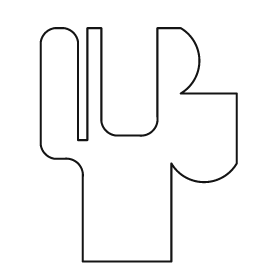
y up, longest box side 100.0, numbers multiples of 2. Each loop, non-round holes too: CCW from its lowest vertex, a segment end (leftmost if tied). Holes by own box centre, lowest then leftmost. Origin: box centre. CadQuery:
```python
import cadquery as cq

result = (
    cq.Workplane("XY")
    .moveTo(-24.0, -50.0)
    .lineTo(14.0, -50.0)
    .lineTo(14.0, -8.0)
    .threePointArc((28.0, -16.0), (42.0, -8.0))
    .lineTo(42.0, 22.0)
    .lineTo(18.0, 22.0)
    .threePointArc((26.0, 36.0), (18.0, 50.0))
    .lineTo(8.0, 50.0)
    .lineTo(8.0, 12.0)
    .threePointArc((6.0, 6.0), (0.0, 4.0))
    .lineTo(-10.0, 4.0)
    .threePointArc((-14.0, 6.0), (-16.0, 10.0))
    .lineTo(-16.0, 50.0)
    .lineTo(-22.0, 50.0)
    .lineTo(-22.0, 2.0)
    .lineTo(-26.0, 2.0)
    .lineTo(-26.0, 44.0)
    .threePointArc((-28.0, 48.0), (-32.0, 50.0))
    .lineTo(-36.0, 50.0)
    .threePointArc((-40.0, 48.0), (-42.0, 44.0))
    .lineTo(-42.0, 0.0)
    .threePointArc((-40.0, -4.0), (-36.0, -6.0))
    .lineTo(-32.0, -6.0)
    .threePointArc((-26.0, -8.0), (-24.0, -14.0))
    .close()
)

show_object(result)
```